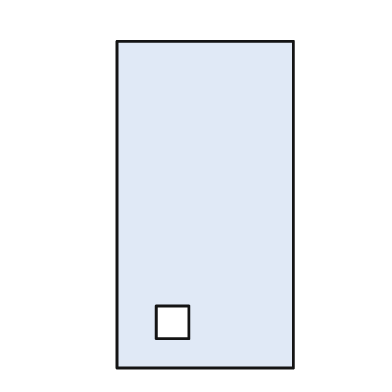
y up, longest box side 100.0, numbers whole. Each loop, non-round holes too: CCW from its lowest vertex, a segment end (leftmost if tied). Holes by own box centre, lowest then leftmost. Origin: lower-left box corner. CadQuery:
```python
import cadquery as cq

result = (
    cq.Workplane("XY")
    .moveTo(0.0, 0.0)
    .lineTo(54.0, 0.0)
    .lineTo(54.0, 100.0)
    .lineTo(0.0, 100.0)
    .close()
    .moveTo(12.0, 9.0)
    .lineTo(22.0, 9.0)
    .lineTo(22.0, 19.0)
    .lineTo(12.0, 19.0)
    .close()
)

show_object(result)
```